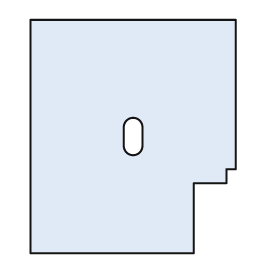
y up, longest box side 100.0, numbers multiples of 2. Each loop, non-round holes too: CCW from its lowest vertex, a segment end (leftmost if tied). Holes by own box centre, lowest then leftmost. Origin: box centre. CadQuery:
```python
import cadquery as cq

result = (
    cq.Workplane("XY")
    .moveTo(-44.0, -50.0)
    .lineTo(26.0, -50.0)
    .lineTo(26.0, -20.0)
    .lineTo(40.0, -20.0)
    .lineTo(40.0, -14.0)
    .lineTo(44.0, -14.0)
    .lineTo(44.0, 50.0)
    .lineTo(-44.0, 50.0)
    .close()
    .moveTo(-4.0, -4.0)
    .threePointArc((0.0, -8.0), (4.0, -4.0))
    .lineTo(4.0, 4.0)
    .threePointArc((0.0, 8.0), (-4.0, 4.0))
    .close()
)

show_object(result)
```